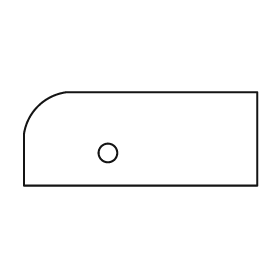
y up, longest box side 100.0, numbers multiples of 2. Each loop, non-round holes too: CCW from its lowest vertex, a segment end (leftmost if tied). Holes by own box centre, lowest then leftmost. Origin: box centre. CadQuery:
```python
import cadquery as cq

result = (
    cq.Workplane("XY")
    .moveTo(-50.0, -20.0)
    .lineTo(50.0, -20.0)
    .lineTo(50.0, 20.0)
    .lineTo(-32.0, 20.0)
    .threePointArc((-44.0, 14.0), (-50.0, 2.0))
    .close()
    .moveTo(-14.0, -6.0)
    .circle(4.0)
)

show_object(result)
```